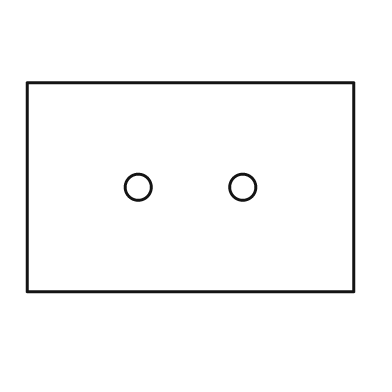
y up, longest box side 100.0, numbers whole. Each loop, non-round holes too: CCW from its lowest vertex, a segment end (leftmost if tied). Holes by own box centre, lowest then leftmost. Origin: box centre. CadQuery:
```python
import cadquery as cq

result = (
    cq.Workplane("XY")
    .moveTo(-50.0, -32.0)
    .lineTo(50.0, -32.0)
    .lineTo(50.0, 32.0)
    .lineTo(-50.0, 32.0)
    .close()
    .moveTo(-16.0, 0.0)
    .circle(4.0)
    .moveTo(16.0, 0.0)
    .circle(4.0)
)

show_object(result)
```